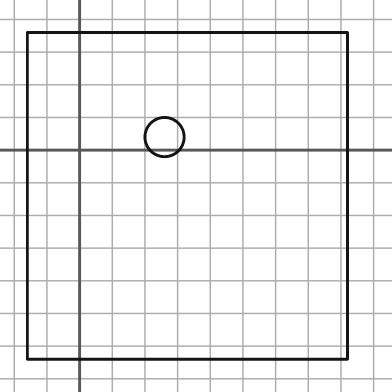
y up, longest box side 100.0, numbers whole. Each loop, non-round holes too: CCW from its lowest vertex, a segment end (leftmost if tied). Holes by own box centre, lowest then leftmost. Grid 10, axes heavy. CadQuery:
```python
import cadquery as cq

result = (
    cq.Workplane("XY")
    .moveTo(-16.0, -64.0)
    .lineTo(82.0, -64.0)
    .lineTo(82.0, 36.0)
    .lineTo(-16.0, 36.0)
    .close()
    .moveTo(26.0, 4.0)
    .circle(6.0)
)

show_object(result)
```